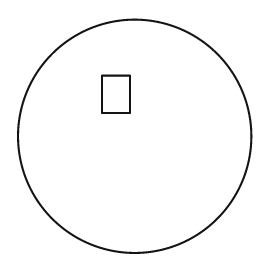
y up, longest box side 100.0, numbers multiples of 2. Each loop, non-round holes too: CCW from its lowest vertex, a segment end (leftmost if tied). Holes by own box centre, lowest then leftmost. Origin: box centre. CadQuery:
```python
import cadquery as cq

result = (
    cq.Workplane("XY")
    .moveTo(0.0, 0.0)
    .circle(50.0)
    .moveTo(-14.0, 10.0)
    .lineTo(-2.0, 10.0)
    .lineTo(-2.0, 26.0)
    .lineTo(-14.0, 26.0)
    .close()
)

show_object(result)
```